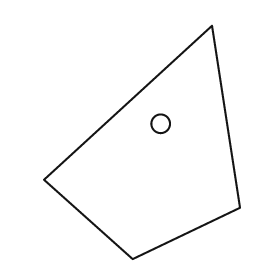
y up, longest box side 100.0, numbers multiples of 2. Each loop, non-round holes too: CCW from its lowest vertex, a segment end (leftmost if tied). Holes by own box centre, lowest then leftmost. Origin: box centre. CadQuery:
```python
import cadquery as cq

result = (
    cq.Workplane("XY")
    .moveTo(-4.0, -50.0)
    .lineTo(42.0, -28.0)
    .lineTo(30.0, 50.0)
    .lineTo(-42.0, -16.0)
    .close()
    .moveTo(8.0, 8.0)
    .circle(4.0)
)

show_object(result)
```